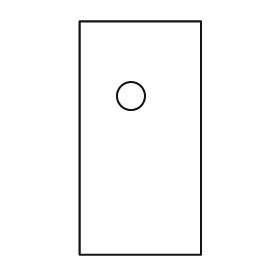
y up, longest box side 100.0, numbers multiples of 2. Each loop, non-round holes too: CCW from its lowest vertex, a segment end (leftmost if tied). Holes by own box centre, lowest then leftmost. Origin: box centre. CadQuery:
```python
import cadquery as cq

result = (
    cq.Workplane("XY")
    .moveTo(-26.0, -50.0)
    .lineTo(26.0, -50.0)
    .lineTo(26.0, 50.0)
    .lineTo(-26.0, 50.0)
    .close()
    .moveTo(-4.0, 18.0)
    .circle(6.0)
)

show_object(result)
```